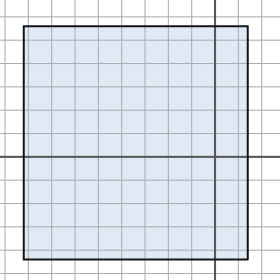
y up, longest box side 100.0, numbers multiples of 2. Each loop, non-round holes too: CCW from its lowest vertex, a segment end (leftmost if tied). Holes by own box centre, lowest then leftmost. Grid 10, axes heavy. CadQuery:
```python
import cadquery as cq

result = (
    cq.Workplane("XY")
    .moveTo(-82.0, -44.0)
    .lineTo(14.0, -44.0)
    .lineTo(14.0, 56.0)
    .lineTo(-82.0, 56.0)
    .close()
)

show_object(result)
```